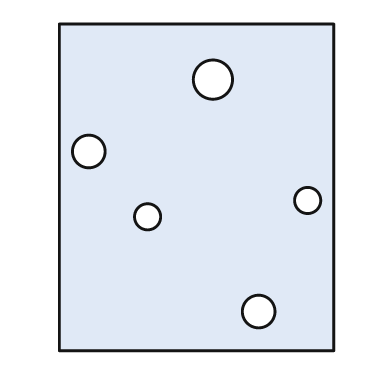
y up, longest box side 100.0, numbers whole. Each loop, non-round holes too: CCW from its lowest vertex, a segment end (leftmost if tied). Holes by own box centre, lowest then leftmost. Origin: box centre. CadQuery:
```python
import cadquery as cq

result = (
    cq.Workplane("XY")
    .moveTo(-42.0, -50.0)
    .lineTo(42.0, -50.0)
    .lineTo(42.0, 50.0)
    .lineTo(-42.0, 50.0)
    .close()
    .moveTo(19.0, -38.0)
    .circle(5.0)
    .moveTo(-15.0, -9.0)
    .circle(4.0)
    .moveTo(34.0, -4.0)
    .circle(4.0)
    .moveTo(-33.0, 11.0)
    .circle(5.0)
    .moveTo(5.0, 33.0)
    .circle(6.0)
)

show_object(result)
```